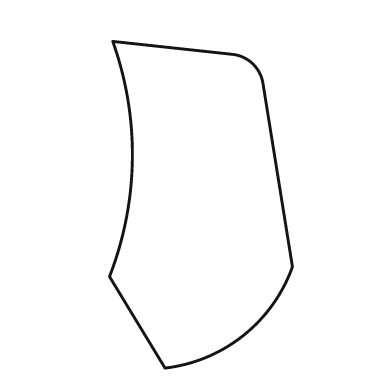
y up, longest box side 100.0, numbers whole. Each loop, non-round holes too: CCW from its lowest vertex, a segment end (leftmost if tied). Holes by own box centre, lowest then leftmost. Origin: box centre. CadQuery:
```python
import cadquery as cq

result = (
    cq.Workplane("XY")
    .moveTo(-11.0, -50.0)
    .threePointArc((13.0, -40.0), (28.0, -19.0))
    .lineTo(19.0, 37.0)
    .threePointArc((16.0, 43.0), (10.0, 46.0))
    .lineTo(-27.0, 50.0)
    .threePointArc((-21.0, 14.0), (-28.0, -22.0))
    .close()
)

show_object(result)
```